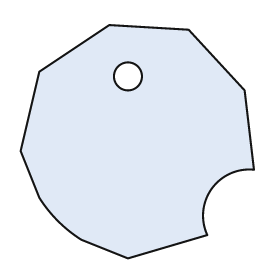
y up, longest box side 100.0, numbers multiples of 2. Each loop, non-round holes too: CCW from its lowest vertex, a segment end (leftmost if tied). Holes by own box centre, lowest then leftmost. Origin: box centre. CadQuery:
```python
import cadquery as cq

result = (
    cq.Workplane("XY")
    .moveTo(-4.0, -50.0)
    .lineTo(30.0, -40.0)
    .threePointArc((32.0, -20.0), (50.0, -12.0))
    .lineTo(46.0, 22.0)
    .lineTo(22.0, 48.0)
    .lineTo(-12.0, 50.0)
    .lineTo(-42.0, 30.0)
    .lineTo(-50.0, -4.0)
    .lineTo(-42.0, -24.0)
    .threePointArc((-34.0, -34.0), (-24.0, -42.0))
    .close()
    .moveTo(-4.0, 28.0)
    .circle(6.0)
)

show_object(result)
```